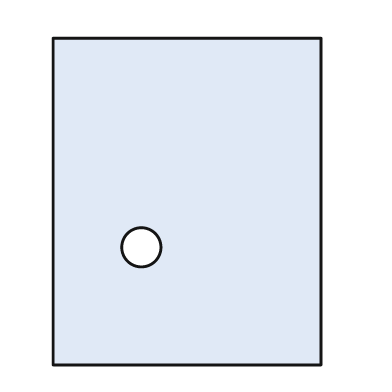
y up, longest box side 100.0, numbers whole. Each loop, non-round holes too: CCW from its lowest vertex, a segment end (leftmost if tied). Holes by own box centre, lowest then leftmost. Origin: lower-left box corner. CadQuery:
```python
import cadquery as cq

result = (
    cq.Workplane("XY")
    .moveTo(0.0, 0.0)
    .lineTo(82.0, 0.0)
    .lineTo(82.0, 100.0)
    .lineTo(0.0, 100.0)
    .close()
    .moveTo(27.0, 36.0)
    .circle(6.0)
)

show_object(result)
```